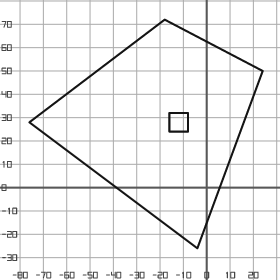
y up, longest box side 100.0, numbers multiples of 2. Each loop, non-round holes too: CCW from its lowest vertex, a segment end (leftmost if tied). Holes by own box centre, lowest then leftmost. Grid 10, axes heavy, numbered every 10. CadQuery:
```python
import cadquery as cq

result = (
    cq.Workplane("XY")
    .moveTo(-4.0, -26.0)
    .lineTo(24.0, 50.0)
    .lineTo(-18.0, 72.0)
    .lineTo(-76.0, 28.0)
    .close()
    .moveTo(-16.0, 24.0)
    .lineTo(-8.0, 24.0)
    .lineTo(-8.0, 32.0)
    .lineTo(-16.0, 32.0)
    .close()
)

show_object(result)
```